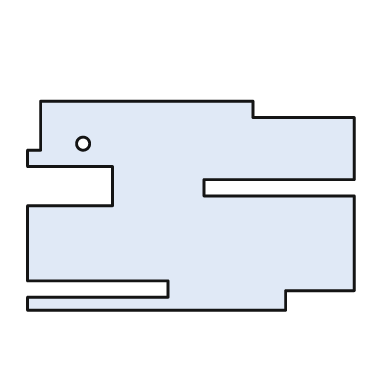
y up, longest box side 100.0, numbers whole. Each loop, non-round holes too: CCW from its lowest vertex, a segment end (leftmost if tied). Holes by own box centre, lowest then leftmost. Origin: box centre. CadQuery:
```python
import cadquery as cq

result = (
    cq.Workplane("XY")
    .moveTo(-50.0, -32.0)
    .lineTo(29.0, -32.0)
    .lineTo(29.0, -26.0)
    .lineTo(50.0, -26.0)
    .lineTo(50.0, 3.0)
    .lineTo(4.0, 3.0)
    .lineTo(4.0, 8.0)
    .lineTo(50.0, 8.0)
    .lineTo(50.0, 27.0)
    .lineTo(19.0, 27.0)
    .lineTo(19.0, 32.0)
    .lineTo(-46.0, 32.0)
    .lineTo(-46.0, 17.0)
    .lineTo(-50.0, 17.0)
    .lineTo(-50.0, 12.0)
    .lineTo(-24.0, 12.0)
    .lineTo(-24.0, 0.0)
    .lineTo(-50.0, 0.0)
    .lineTo(-50.0, -23.0)
    .lineTo(-7.0, -23.0)
    .lineTo(-7.0, -28.0)
    .lineTo(-50.0, -28.0)
    .close()
    .moveTo(-33.0, 19.0)
    .circle(2.0)
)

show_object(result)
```